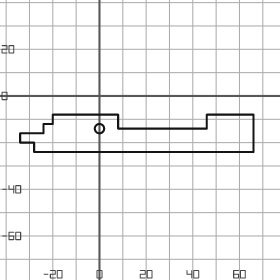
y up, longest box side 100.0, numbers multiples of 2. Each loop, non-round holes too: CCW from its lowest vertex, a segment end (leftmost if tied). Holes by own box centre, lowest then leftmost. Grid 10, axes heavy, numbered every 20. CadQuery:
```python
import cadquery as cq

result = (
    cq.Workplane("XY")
    .moveTo(-28.0, -24.0)
    .lineTo(66.0, -24.0)
    .lineTo(66.0, -8.0)
    .lineTo(46.0, -8.0)
    .lineTo(46.0, -14.0)
    .lineTo(8.0, -14.0)
    .lineTo(8.0, -8.0)
    .lineTo(-20.0, -8.0)
    .lineTo(-20.0, -12.0)
    .lineTo(-24.0, -12.0)
    .lineTo(-24.0, -16.0)
    .lineTo(-34.0, -16.0)
    .lineTo(-34.0, -20.0)
    .lineTo(-28.0, -20.0)
    .close()
    .moveTo(0.0, -14.0)
    .circle(2.0)
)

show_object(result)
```